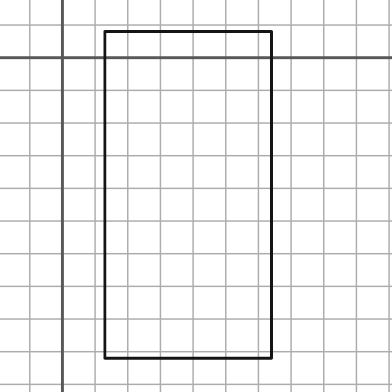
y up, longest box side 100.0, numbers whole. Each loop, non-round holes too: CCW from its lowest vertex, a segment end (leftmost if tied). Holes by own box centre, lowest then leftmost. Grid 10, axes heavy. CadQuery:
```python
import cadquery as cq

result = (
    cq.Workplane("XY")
    .moveTo(13.0, -92.0)
    .lineTo(64.0, -92.0)
    .lineTo(64.0, 8.0)
    .lineTo(13.0, 8.0)
    .close()
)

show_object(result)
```